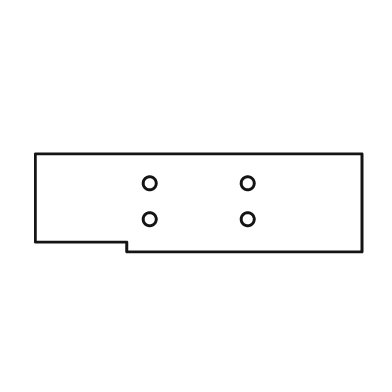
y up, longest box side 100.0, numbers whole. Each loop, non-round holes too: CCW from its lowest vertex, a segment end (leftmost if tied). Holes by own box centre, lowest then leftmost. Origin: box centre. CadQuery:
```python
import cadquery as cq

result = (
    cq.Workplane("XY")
    .moveTo(-22.0, -15.0)
    .lineTo(50.0, -15.0)
    .lineTo(50.0, 15.0)
    .lineTo(-50.0, 15.0)
    .lineTo(-50.0, -12.0)
    .lineTo(-22.0, -12.0)
    .close()
    .moveTo(-15.0, -5.0)
    .circle(2.0)
    .moveTo(15.0, -5.0)
    .circle(2.0)
    .moveTo(-15.0, 6.0)
    .circle(2.0)
    .moveTo(15.0, 6.0)
    .circle(2.0)
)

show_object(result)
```